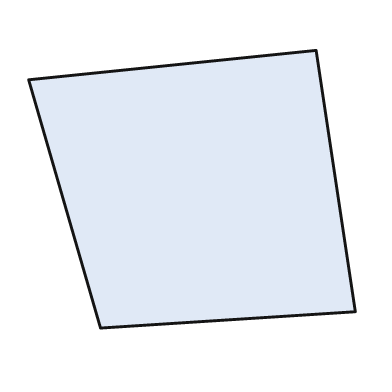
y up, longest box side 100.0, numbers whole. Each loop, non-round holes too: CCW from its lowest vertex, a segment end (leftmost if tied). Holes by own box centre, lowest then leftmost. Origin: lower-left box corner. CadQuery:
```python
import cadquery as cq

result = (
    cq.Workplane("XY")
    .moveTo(22.0, 0.0)
    .lineTo(100.0, 5.0)
    .lineTo(88.0, 85.0)
    .lineTo(0.0, 76.0)
    .close()
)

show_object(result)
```